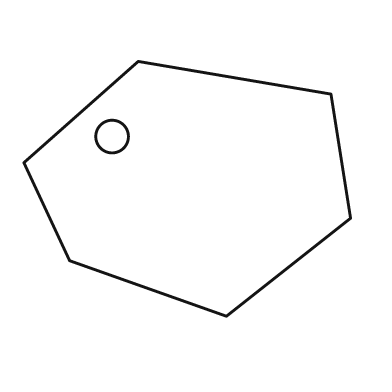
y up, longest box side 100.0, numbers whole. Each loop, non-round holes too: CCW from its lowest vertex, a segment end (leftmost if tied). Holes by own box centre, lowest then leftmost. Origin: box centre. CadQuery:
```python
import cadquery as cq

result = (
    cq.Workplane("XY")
    .moveTo(12.0, -39.0)
    .lineTo(50.0, -9.0)
    .lineTo(44.0, 29.0)
    .lineTo(-15.0, 39.0)
    .lineTo(-50.0, 8.0)
    .lineTo(-36.0, -22.0)
    .close()
    .moveTo(-23.0, 16.0)
    .circle(5.0)
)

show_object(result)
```